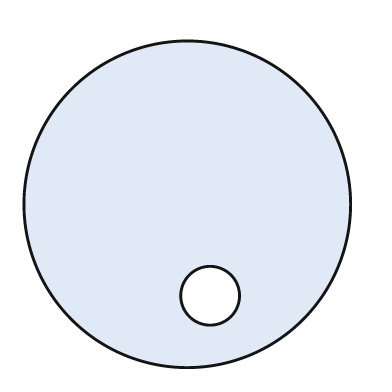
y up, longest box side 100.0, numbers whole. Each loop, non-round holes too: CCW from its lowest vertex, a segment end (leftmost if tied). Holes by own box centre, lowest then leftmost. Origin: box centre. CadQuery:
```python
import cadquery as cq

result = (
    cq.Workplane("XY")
    .moveTo(0.0, 0.0)
    .circle(50.0)
    .moveTo(7.0, -28.0)
    .circle(9.0)
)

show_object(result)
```